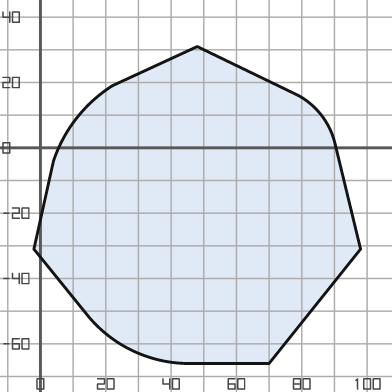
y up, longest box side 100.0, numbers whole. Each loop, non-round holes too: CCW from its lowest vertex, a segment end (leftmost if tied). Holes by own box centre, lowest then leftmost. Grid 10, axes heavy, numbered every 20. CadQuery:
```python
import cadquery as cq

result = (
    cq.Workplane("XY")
    .moveTo(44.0, -66.0)
    .lineTo(70.0, -66.0)
    .lineTo(98.0, -31.0)
    .lineTo(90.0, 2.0)
    .threePointArc((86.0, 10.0), (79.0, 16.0))
    .lineTo(48.0, 31.0)
    .lineTo(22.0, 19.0)
    .threePointArc((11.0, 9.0), (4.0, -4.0))
    .lineTo(-2.0, -31.0)
    .lineTo(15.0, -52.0)
    .threePointArc((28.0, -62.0), (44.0, -66.0))
    .close()
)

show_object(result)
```